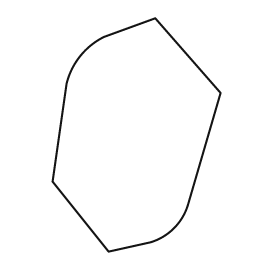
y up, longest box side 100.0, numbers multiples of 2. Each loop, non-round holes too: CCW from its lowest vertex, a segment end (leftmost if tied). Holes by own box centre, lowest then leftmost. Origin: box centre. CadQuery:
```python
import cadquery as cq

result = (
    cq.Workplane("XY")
    .moveTo(-12.0, -50.0)
    .lineTo(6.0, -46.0)
    .threePointArc((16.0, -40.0), (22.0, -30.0))
    .lineTo(36.0, 18.0)
    .lineTo(8.0, 50.0)
    .lineTo(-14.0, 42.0)
    .threePointArc((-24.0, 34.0), (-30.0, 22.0))
    .lineTo(-36.0, -20.0)
    .close()
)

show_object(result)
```